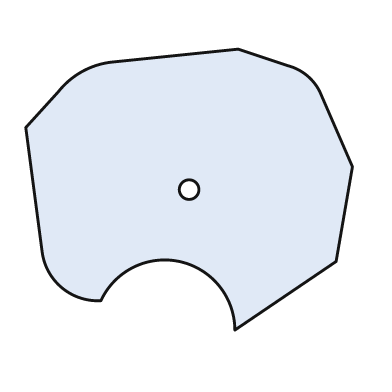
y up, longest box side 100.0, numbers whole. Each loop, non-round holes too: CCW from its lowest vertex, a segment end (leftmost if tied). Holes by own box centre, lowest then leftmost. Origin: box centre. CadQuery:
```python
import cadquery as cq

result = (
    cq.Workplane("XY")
    .moveTo(14.0, -43.0)
    .lineTo(45.0, -22.0)
    .lineTo(50.0, 7.0)
    .lineTo(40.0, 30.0)
    .threePointArc((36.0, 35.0), (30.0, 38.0))
    .lineTo(15.0, 43.0)
    .lineTo(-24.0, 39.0)
    .threePointArc((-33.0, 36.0), (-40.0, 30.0))
    .lineTo(-50.0, 19.0)
    .lineTo(-45.0, -19.0)
    .threePointArc((-39.0, -30.0), (-27.0, -34.0))
    .threePointArc((-3.0, -22.0), (14.0, -43.0))
    .close()
    .moveTo(0.0, 0.0)
    .circle(3.0)
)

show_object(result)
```